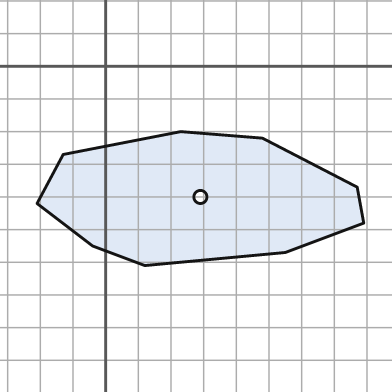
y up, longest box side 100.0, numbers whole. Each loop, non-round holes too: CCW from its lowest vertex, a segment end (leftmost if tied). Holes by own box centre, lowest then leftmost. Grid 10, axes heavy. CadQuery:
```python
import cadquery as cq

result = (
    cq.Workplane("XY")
    .moveTo(12.0, -61.0)
    .lineTo(55.0, -57.0)
    .lineTo(79.0, -48.0)
    .lineTo(77.0, -37.0)
    .lineTo(48.0, -22.0)
    .lineTo(23.0, -20.0)
    .lineTo(-13.0, -27.0)
    .lineTo(-21.0, -42.0)
    .lineTo(-4.0, -55.0)
    .close()
    .moveTo(29.0, -40.0)
    .circle(2.0)
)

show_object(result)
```